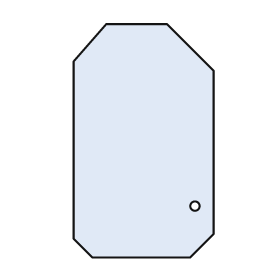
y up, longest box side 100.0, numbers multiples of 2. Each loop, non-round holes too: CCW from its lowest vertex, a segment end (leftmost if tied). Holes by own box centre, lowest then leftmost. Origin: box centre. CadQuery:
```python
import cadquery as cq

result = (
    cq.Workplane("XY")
    .moveTo(-22.0, -50.0)
    .lineTo(20.0, -50.0)
    .lineTo(30.0, -40.0)
    .lineTo(30.0, 30.0)
    .lineTo(10.0, 50.0)
    .lineTo(-16.0, 50.0)
    .lineTo(-30.0, 34.0)
    .lineTo(-30.0, -42.0)
    .close()
    .moveTo(22.0, -28.0)
    .circle(2.0)
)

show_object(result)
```